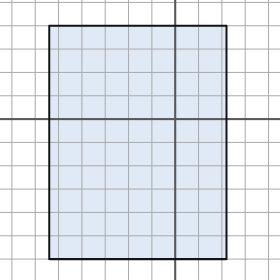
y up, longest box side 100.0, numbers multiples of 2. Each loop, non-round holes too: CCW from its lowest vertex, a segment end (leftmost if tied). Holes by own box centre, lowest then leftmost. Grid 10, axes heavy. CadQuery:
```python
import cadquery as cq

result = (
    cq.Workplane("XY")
    .moveTo(-54.0, -60.0)
    .lineTo(22.0, -60.0)
    .lineTo(22.0, 40.0)
    .lineTo(-54.0, 40.0)
    .close()
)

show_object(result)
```